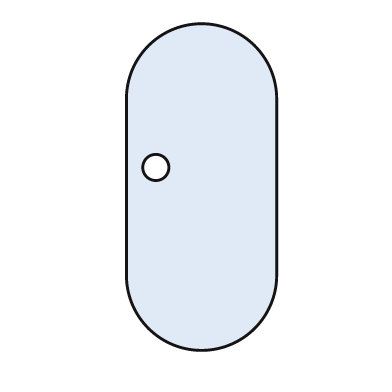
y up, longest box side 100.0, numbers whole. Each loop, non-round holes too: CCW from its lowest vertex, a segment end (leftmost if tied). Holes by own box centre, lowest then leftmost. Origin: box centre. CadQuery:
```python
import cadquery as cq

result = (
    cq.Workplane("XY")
    .moveTo(-23.0, -27.0)
    .threePointArc((0.0, -50.0), (23.0, -27.0))
    .lineTo(23.0, 27.0)
    .threePointArc((0.0, 50.0), (-23.0, 27.0))
    .close()
    .moveTo(-14.0, 6.0)
    .circle(4.0)
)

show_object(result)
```